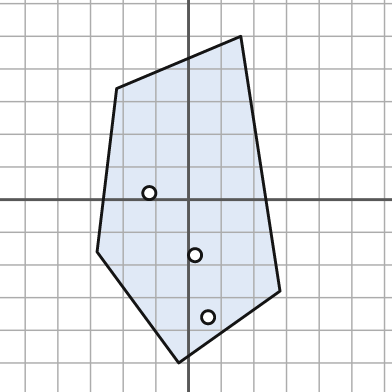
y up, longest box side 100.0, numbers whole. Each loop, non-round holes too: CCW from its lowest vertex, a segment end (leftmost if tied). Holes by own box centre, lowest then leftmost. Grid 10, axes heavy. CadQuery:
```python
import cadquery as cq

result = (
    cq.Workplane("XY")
    .moveTo(-3.0, -50.0)
    .lineTo(28.0, -28.0)
    .lineTo(16.0, 50.0)
    .lineTo(-22.0, 34.0)
    .lineTo(-28.0, -16.0)
    .close()
    .moveTo(6.0, -36.0)
    .circle(2.0)
    .moveTo(2.0, -17.0)
    .circle(2.0)
    .moveTo(-12.0, 2.0)
    .circle(2.0)
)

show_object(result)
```